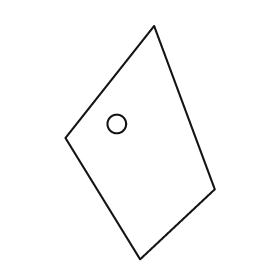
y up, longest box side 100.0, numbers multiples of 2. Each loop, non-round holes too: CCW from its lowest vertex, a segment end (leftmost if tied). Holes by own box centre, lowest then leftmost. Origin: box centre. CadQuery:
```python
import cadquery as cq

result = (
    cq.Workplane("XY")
    .moveTo(0.0, -50.0)
    .lineTo(32.0, -20.0)
    .lineTo(6.0, 50.0)
    .lineTo(-32.0, 2.0)
    .close()
    .moveTo(-10.0, 8.0)
    .circle(4.0)
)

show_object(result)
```